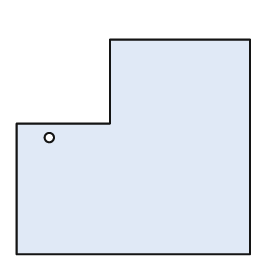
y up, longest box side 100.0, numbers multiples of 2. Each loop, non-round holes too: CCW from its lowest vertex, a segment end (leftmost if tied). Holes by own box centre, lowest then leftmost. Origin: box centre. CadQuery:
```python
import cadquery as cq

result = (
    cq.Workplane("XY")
    .moveTo(-50.0, -46.0)
    .lineTo(50.0, -46.0)
    .lineTo(50.0, 46.0)
    .lineTo(-10.0, 46.0)
    .lineTo(-10.0, 10.0)
    .lineTo(-50.0, 10.0)
    .close()
    .moveTo(-36.0, 4.0)
    .circle(2.0)
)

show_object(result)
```